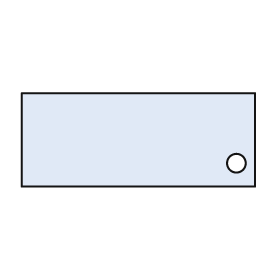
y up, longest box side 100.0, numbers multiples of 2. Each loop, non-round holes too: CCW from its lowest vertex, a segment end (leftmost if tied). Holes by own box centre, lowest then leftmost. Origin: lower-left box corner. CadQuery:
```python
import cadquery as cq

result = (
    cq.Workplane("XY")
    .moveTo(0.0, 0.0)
    .lineTo(100.0, 0.0)
    .lineTo(100.0, 40.0)
    .lineTo(0.0, 40.0)
    .close()
    .moveTo(92.0, 10.0)
    .circle(4.0)
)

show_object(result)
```